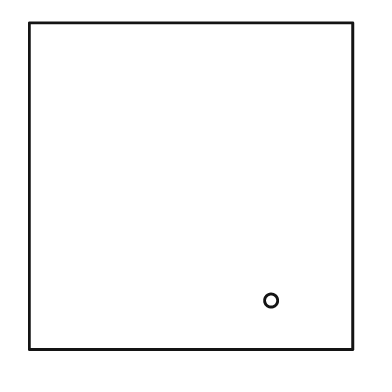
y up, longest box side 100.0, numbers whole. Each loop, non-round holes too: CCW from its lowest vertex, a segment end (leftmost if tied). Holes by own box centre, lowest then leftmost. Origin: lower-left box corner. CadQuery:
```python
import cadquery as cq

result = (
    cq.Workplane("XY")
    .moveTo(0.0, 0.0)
    .lineTo(99.0, 0.0)
    .lineTo(99.0, 100.0)
    .lineTo(0.0, 100.0)
    .close()
    .moveTo(74.0, 15.0)
    .circle(2.0)
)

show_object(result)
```